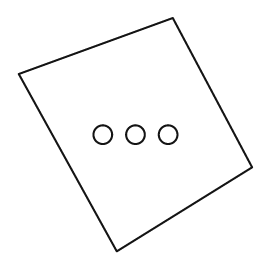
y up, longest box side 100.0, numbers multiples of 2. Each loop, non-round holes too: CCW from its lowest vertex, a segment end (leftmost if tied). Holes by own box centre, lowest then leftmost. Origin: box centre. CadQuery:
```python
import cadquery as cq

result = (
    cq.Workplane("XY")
    .moveTo(-8.0, -50.0)
    .lineTo(50.0, -14.0)
    .lineTo(16.0, 50.0)
    .lineTo(-50.0, 26.0)
    .close()
    .moveTo(-14.0, 0.0)
    .circle(4.0)
    .moveTo(0.0, 0.0)
    .circle(4.0)
    .moveTo(14.0, 0.0)
    .circle(4.0)
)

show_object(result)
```